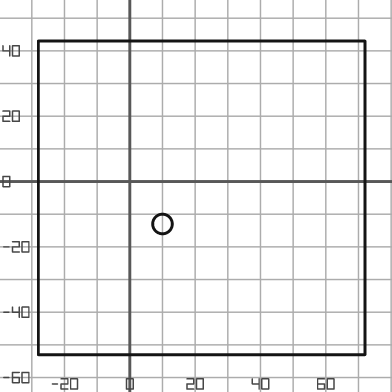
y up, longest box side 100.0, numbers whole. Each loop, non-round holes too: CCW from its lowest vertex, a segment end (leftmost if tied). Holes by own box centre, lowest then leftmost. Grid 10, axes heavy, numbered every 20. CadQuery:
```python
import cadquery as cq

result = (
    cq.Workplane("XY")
    .moveTo(-28.0, -53.0)
    .lineTo(72.0, -53.0)
    .lineTo(72.0, 43.0)
    .lineTo(-28.0, 43.0)
    .close()
    .moveTo(10.0, -13.0)
    .circle(3.0)
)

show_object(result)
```